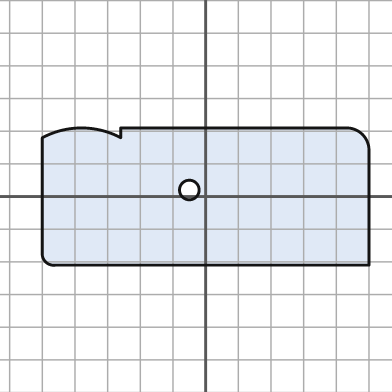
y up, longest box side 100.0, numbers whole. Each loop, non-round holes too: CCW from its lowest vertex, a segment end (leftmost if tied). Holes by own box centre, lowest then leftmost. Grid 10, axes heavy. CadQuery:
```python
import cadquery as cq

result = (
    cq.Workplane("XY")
    .moveTo(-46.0, -21.0)
    .lineTo(50.0, -21.0)
    .lineTo(50.0, 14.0)
    .threePointArc((48.0, 19.0), (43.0, 21.0))
    .lineTo(-26.0, 21.0)
    .lineTo(-26.0, 18.0)
    .threePointArc((-38.0, 21.0), (-50.0, 18.0))
    .lineTo(-50.0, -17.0)
    .threePointArc((-49.0, -20.0), (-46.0, -21.0))
    .close()
    .moveTo(-5.0, 2.0)
    .circle(3.0)
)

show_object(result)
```